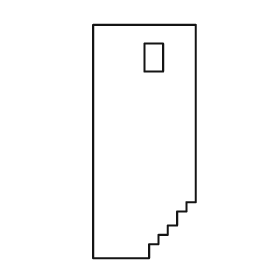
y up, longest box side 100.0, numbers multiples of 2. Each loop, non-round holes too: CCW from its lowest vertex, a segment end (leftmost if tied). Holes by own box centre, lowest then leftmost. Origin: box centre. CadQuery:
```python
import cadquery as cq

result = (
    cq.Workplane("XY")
    .moveTo(-22.0, -50.0)
    .lineTo(2.0, -50.0)
    .lineTo(2.0, -44.0)
    .lineTo(6.0, -44.0)
    .lineTo(6.0, -40.0)
    .lineTo(10.0, -40.0)
    .lineTo(10.0, -36.0)
    .lineTo(14.0, -36.0)
    .lineTo(14.0, -30.0)
    .lineTo(18.0, -30.0)
    .lineTo(18.0, -26.0)
    .lineTo(22.0, -26.0)
    .lineTo(22.0, 50.0)
    .lineTo(-22.0, 50.0)
    .close()
    .moveTo(0.0, 30.0)
    .lineTo(8.0, 30.0)
    .lineTo(8.0, 42.0)
    .lineTo(0.0, 42.0)
    .close()
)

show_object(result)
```